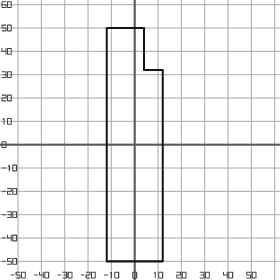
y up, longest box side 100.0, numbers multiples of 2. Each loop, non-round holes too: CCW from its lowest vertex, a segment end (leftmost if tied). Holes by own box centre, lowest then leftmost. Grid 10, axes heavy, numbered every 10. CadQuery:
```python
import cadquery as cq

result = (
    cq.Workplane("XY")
    .moveTo(-12.0, -50.0)
    .lineTo(12.0, -50.0)
    .lineTo(12.0, 32.0)
    .lineTo(4.0, 32.0)
    .lineTo(4.0, 50.0)
    .lineTo(-12.0, 50.0)
    .close()
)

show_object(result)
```